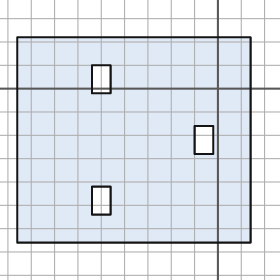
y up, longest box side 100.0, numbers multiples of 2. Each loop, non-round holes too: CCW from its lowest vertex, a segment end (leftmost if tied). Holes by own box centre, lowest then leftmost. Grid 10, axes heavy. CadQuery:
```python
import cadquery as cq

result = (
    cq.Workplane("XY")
    .moveTo(-86.0, -66.0)
    .lineTo(14.0, -66.0)
    .lineTo(14.0, 22.0)
    .lineTo(-86.0, 22.0)
    .close()
    .moveTo(-54.0, -54.0)
    .lineTo(-46.0, -54.0)
    .lineTo(-46.0, -42.0)
    .lineTo(-54.0, -42.0)
    .close()
    .moveTo(-10.0, -28.0)
    .lineTo(-2.0, -28.0)
    .lineTo(-2.0, -16.0)
    .lineTo(-10.0, -16.0)
    .close()
    .moveTo(-54.0, -2.0)
    .lineTo(-46.0, -2.0)
    .lineTo(-46.0, 10.0)
    .lineTo(-54.0, 10.0)
    .close()
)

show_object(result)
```